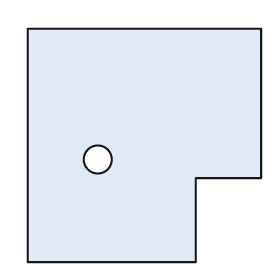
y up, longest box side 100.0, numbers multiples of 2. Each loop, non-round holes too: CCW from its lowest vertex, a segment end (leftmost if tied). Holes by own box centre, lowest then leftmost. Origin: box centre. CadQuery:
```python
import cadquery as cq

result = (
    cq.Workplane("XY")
    .moveTo(-50.0, -50.0)
    .lineTo(22.0, -50.0)
    .lineTo(22.0, -14.0)
    .lineTo(50.0, -14.0)
    .lineTo(50.0, 50.0)
    .lineTo(-50.0, 50.0)
    .close()
    .moveTo(-20.0, -6.0)
    .circle(6.0)
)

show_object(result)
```